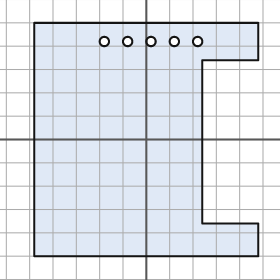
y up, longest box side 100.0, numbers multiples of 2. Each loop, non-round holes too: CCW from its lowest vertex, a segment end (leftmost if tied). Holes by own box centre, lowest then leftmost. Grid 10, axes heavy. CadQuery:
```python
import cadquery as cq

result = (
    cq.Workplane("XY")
    .moveTo(-48.0, -50.0)
    .lineTo(48.0, -50.0)
    .lineTo(48.0, -36.0)
    .lineTo(24.0, -36.0)
    .lineTo(24.0, 34.0)
    .lineTo(48.0, 34.0)
    .lineTo(48.0, 50.0)
    .lineTo(-48.0, 50.0)
    .close()
    .moveTo(-18.0, 42.0)
    .circle(2.0)
    .moveTo(-8.0, 42.0)
    .circle(2.0)
    .moveTo(2.0, 42.0)
    .circle(2.0)
    .moveTo(12.0, 42.0)
    .circle(2.0)
    .moveTo(22.0, 42.0)
    .circle(2.0)
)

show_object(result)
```